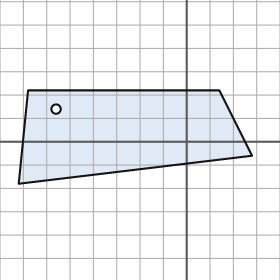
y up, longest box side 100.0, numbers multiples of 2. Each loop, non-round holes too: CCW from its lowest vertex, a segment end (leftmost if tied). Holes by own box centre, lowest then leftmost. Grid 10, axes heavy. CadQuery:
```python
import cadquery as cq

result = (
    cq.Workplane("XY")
    .moveTo(-72.0, -18.0)
    .lineTo(28.0, -6.0)
    .lineTo(14.0, 22.0)
    .lineTo(-68.0, 22.0)
    .close()
    .moveTo(-56.0, 14.0)
    .circle(2.0)
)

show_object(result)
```